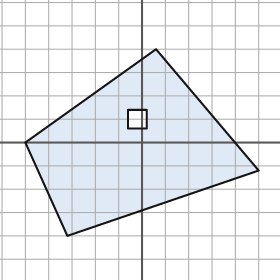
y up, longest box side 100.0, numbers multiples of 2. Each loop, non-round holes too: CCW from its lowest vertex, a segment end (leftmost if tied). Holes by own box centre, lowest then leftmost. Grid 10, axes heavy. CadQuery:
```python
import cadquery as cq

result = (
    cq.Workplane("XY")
    .moveTo(-32.0, -40.0)
    .lineTo(50.0, -12.0)
    .lineTo(6.0, 40.0)
    .lineTo(-50.0, 0.0)
    .close()
    .moveTo(-6.0, 6.0)
    .lineTo(2.0, 6.0)
    .lineTo(2.0, 14.0)
    .lineTo(-6.0, 14.0)
    .close()
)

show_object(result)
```